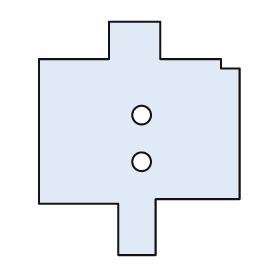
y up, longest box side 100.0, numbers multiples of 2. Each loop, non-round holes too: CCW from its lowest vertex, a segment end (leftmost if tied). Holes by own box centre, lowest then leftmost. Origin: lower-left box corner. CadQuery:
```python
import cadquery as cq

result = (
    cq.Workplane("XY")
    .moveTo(34.0, 0.0)
    .lineTo(50.0, 0.0)
    .lineTo(50.0, 24.0)
    .lineTo(86.0, 24.0)
    .lineTo(86.0, 80.0)
    .lineTo(78.0, 80.0)
    .lineTo(78.0, 84.0)
    .lineTo(52.0, 84.0)
    .lineTo(52.0, 100.0)
    .lineTo(30.0, 100.0)
    .lineTo(30.0, 84.0)
    .lineTo(0.0, 84.0)
    .lineTo(0.0, 22.0)
    .lineTo(34.0, 22.0)
    .close()
    .moveTo(44.0, 40.0)
    .circle(4.0)
    .moveTo(44.0, 60.0)
    .circle(4.0)
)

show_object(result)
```